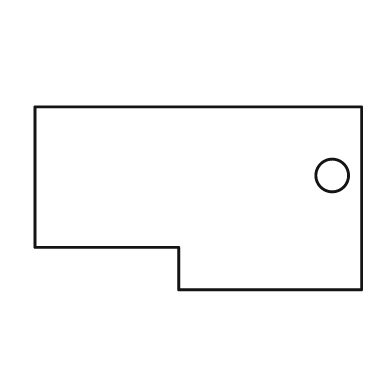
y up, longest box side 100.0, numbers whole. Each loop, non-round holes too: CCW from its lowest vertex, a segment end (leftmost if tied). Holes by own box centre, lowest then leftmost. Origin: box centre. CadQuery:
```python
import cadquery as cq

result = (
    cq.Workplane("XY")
    .moveTo(-6.0, -28.0)
    .lineTo(50.0, -28.0)
    .lineTo(50.0, 28.0)
    .lineTo(-50.0, 28.0)
    .lineTo(-50.0, -15.0)
    .lineTo(-6.0, -15.0)
    .close()
    .moveTo(41.0, 7.0)
    .circle(5.0)
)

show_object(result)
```